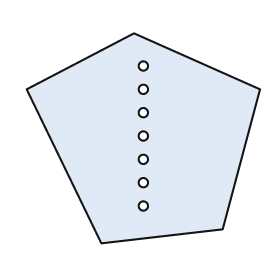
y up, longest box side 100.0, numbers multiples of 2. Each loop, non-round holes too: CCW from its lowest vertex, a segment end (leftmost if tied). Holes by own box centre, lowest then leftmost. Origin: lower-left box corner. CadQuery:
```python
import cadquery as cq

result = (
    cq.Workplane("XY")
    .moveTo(32.0, 0.0)
    .lineTo(84.0, 6.0)
    .lineTo(100.0, 66.0)
    .lineTo(46.0, 90.0)
    .lineTo(0.0, 66.0)
    .close()
    .moveTo(50.0, 16.0)
    .circle(2.0)
    .moveTo(50.0, 26.0)
    .circle(2.0)
    .moveTo(50.0, 36.0)
    .circle(2.0)
    .moveTo(50.0, 46.0)
    .circle(2.0)
    .moveTo(50.0, 56.0)
    .circle(2.0)
    .moveTo(50.0, 66.0)
    .circle(2.0)
    .moveTo(50.0, 76.0)
    .circle(2.0)
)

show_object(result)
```